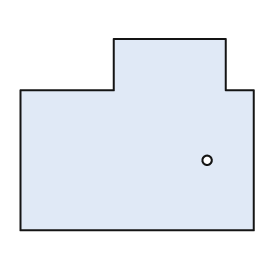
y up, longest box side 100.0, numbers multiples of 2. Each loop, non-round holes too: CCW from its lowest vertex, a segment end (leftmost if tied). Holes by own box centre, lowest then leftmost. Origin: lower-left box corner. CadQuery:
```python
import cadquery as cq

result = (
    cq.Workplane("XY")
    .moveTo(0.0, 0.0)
    .lineTo(100.0, 0.0)
    .lineTo(100.0, 60.0)
    .lineTo(88.0, 60.0)
    .lineTo(88.0, 82.0)
    .lineTo(40.0, 82.0)
    .lineTo(40.0, 60.0)
    .lineTo(0.0, 60.0)
    .close()
    .moveTo(80.0, 30.0)
    .circle(2.0)
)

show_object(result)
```